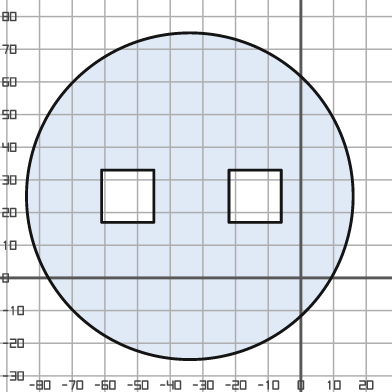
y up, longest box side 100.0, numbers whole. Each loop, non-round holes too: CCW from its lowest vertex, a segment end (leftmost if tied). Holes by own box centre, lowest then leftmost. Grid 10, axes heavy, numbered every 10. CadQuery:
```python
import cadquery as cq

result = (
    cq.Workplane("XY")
    .moveTo(-34.0, 25.0)
    .circle(50.0)
    .moveTo(-61.0, 17.0)
    .lineTo(-45.0, 17.0)
    .lineTo(-45.0, 33.0)
    .lineTo(-61.0, 33.0)
    .close()
    .moveTo(-22.0, 17.0)
    .lineTo(-6.0, 17.0)
    .lineTo(-6.0, 33.0)
    .lineTo(-22.0, 33.0)
    .close()
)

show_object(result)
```